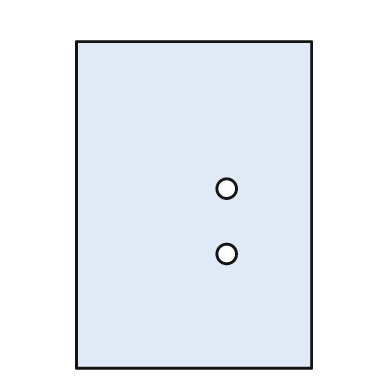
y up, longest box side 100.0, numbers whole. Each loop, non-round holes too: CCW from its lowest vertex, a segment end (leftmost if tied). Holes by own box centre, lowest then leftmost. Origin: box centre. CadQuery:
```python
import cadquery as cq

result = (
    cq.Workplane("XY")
    .moveTo(-36.0, -50.0)
    .lineTo(36.0, -50.0)
    .lineTo(36.0, 50.0)
    .lineTo(-36.0, 50.0)
    .close()
    .moveTo(10.0, -15.0)
    .circle(3.0)
    .moveTo(10.0, 5.0)
    .circle(3.0)
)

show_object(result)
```